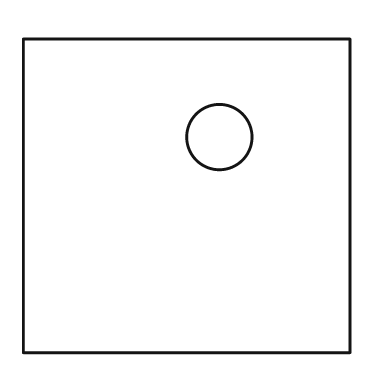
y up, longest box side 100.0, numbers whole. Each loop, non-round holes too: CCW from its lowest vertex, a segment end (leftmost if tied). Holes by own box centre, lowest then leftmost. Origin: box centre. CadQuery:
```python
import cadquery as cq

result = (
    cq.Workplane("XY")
    .moveTo(-50.0, -48.0)
    .lineTo(50.0, -48.0)
    .lineTo(50.0, 48.0)
    .lineTo(-50.0, 48.0)
    .close()
    .moveTo(10.0, 18.0)
    .circle(10.0)
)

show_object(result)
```